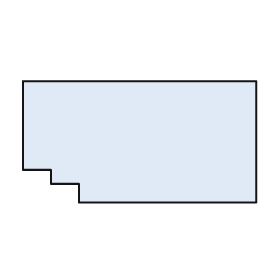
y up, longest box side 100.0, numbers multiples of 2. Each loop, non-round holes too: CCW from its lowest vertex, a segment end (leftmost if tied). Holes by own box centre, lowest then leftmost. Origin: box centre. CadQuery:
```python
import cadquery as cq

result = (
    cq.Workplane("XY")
    .moveTo(-26.0, -26.0)
    .lineTo(50.0, -26.0)
    .lineTo(50.0, 26.0)
    .lineTo(-50.0, 26.0)
    .lineTo(-50.0, -12.0)
    .lineTo(-38.0, -12.0)
    .lineTo(-38.0, -18.0)
    .lineTo(-26.0, -18.0)
    .close()
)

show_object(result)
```